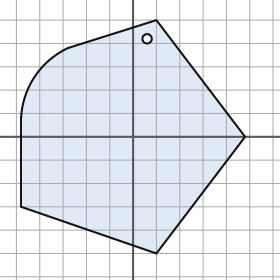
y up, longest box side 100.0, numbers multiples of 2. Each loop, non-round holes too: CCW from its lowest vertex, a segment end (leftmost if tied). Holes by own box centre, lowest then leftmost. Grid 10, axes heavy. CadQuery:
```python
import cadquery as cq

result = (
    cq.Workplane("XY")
    .moveTo(10.0, -50.0)
    .lineTo(48.0, 0.0)
    .lineTo(10.0, 50.0)
    .lineTo(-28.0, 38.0)
    .threePointArc((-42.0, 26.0), (-48.0, 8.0))
    .lineTo(-48.0, -30.0)
    .close()
    .moveTo(6.0, 42.0)
    .circle(2.0)
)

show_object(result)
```